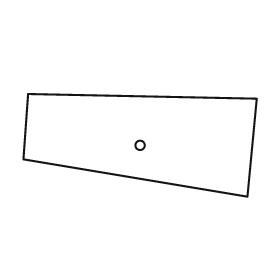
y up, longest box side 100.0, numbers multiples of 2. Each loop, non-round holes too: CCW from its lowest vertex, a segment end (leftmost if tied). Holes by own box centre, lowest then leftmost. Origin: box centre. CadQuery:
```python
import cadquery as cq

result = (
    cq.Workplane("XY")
    .moveTo(46.0, -22.0)
    .lineTo(50.0, 20.0)
    .lineTo(-48.0, 22.0)
    .lineTo(-50.0, -6.0)
    .close()
    .moveTo(0.0, 0.0)
    .circle(2.0)
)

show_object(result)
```